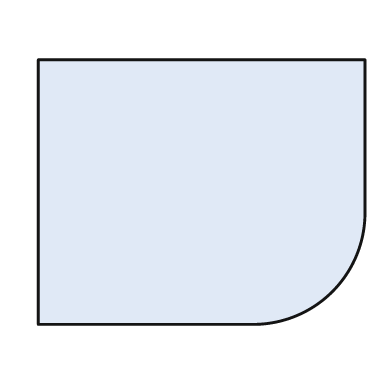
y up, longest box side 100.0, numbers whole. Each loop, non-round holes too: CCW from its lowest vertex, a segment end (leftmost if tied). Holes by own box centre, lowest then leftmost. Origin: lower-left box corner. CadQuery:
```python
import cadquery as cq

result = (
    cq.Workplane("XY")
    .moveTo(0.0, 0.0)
    .lineTo(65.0, 0.0)
    .threePointArc((90.0, 10.0), (100.0, 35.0))
    .lineTo(100.0, 81.0)
    .lineTo(0.0, 81.0)
    .close()
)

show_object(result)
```